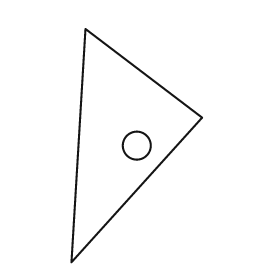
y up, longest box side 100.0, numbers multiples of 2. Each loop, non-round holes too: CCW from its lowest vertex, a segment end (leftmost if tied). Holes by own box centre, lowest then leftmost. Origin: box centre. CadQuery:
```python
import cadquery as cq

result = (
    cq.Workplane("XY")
    .moveTo(-28.0, -50.0)
    .lineTo(28.0, 12.0)
    .lineTo(-22.0, 50.0)
    .close()
    .moveTo(0.0, 0.0)
    .circle(6.0)
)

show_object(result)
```